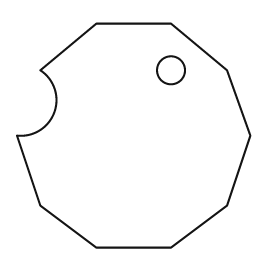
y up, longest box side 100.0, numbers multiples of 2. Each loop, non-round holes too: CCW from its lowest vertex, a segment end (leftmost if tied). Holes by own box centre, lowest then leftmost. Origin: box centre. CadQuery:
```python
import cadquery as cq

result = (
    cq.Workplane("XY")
    .moveTo(-16.0, -48.0)
    .lineTo(16.0, -48.0)
    .lineTo(40.0, -30.0)
    .lineTo(50.0, 0.0)
    .lineTo(40.0, 28.0)
    .lineTo(16.0, 48.0)
    .lineTo(-16.0, 48.0)
    .lineTo(-40.0, 28.0)
    .threePointArc((-34.0, 10.0), (-50.0, 0.0))
    .lineTo(-40.0, -30.0)
    .close()
    .moveTo(16.0, 28.0)
    .circle(6.0)
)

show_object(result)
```